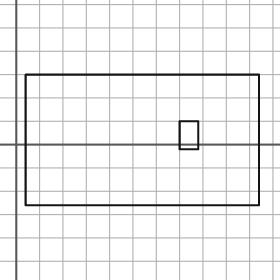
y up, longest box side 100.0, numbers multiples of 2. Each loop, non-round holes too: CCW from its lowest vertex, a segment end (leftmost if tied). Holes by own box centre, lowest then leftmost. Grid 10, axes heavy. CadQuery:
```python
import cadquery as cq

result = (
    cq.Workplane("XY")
    .moveTo(4.0, -26.0)
    .lineTo(104.0, -26.0)
    .lineTo(104.0, 30.0)
    .lineTo(4.0, 30.0)
    .close()
    .moveTo(70.0, -2.0)
    .lineTo(78.0, -2.0)
    .lineTo(78.0, 10.0)
    .lineTo(70.0, 10.0)
    .close()
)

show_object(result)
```